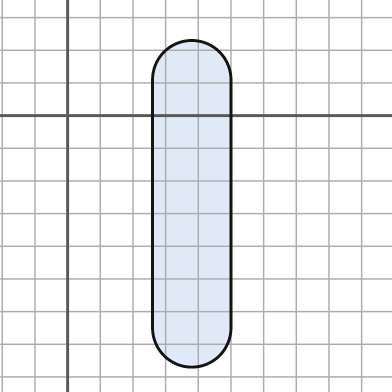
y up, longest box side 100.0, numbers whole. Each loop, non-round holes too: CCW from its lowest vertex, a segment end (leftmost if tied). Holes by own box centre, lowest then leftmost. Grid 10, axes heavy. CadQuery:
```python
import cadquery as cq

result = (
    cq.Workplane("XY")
    .moveTo(26.0, -65.0)
    .threePointArc((38.0, -77.0), (50.0, -65.0))
    .lineTo(50.0, 11.0)
    .threePointArc((38.0, 23.0), (26.0, 11.0))
    .close()
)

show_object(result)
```